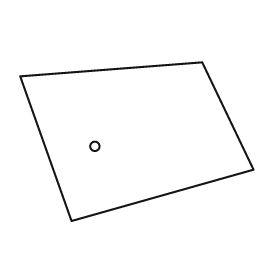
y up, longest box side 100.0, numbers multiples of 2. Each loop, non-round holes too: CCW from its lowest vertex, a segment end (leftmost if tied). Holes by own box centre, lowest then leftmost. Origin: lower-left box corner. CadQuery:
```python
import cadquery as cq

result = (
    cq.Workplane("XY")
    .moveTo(22.0, 0.0)
    .lineTo(100.0, 22.0)
    .lineTo(78.0, 68.0)
    .lineTo(0.0, 62.0)
    .close()
    .moveTo(32.0, 32.0)
    .circle(2.0)
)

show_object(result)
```